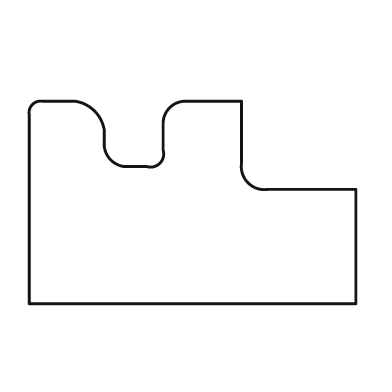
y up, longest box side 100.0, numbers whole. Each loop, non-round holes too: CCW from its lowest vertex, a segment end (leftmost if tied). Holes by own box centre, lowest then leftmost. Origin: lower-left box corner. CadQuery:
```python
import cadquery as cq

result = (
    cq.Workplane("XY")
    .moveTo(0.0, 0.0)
    .lineTo(100.0, 0.0)
    .lineTo(100.0, 35.0)
    .lineTo(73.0, 35.0)
    .threePointArc((67.0, 37.0), (65.0, 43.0))
    .lineTo(65.0, 62.0)
    .lineTo(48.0, 62.0)
    .threePointArc((43.0, 60.0), (41.0, 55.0))
    .lineTo(41.0, 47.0)
    .threePointArc((40.0, 43.0), (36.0, 42.0))
    .lineTo(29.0, 42.0)
    .threePointArc((25.0, 44.0), (23.0, 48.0))
    .lineTo(23.0, 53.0)
    .threePointArc((20.0, 59.0), (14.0, 62.0))
    .lineTo(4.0, 62.0)
    .threePointArc((1.0, 61.0), (0.0, 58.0))
    .close()
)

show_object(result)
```